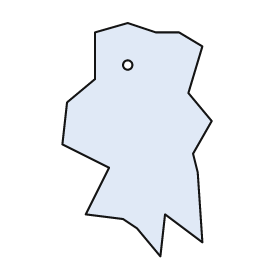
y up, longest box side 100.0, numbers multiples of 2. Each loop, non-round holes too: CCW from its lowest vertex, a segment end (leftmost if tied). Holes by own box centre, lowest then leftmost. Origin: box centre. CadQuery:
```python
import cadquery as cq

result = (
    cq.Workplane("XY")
    .moveTo(10.0, -50.0)
    .lineTo(12.0, -32.0)
    .lineTo(28.0, -44.0)
    .lineTo(26.0, -14.0)
    .lineTo(24.0, -6.0)
    .lineTo(32.0, 8.0)
    .lineTo(22.0, 20.0)
    .lineTo(28.0, 40.0)
    .lineTo(18.0, 46.0)
    .lineTo(8.0, 46.0)
    .lineTo(-4.0, 50.0)
    .lineTo(-18.0, 46.0)
    .lineTo(-18.0, 26.0)
    .lineTo(-30.0, 16.0)
    .lineTo(-32.0, -2.0)
    .lineTo(-12.0, -12.0)
    .lineTo(-22.0, -32.0)
    .lineTo(-6.0, -34.0)
    .lineTo(0.0, -38.0)
    .close()
    .moveTo(-4.0, 32.0)
    .circle(2.0)
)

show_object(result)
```